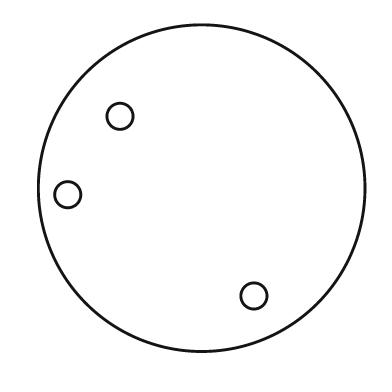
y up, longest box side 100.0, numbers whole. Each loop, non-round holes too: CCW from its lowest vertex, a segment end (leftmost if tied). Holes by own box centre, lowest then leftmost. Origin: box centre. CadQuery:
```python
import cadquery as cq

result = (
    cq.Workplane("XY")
    .moveTo(0.0, 0.0)
    .circle(50.0)
    .moveTo(16.0, -33.0)
    .circle(4.0)
    .moveTo(-41.0, -2.0)
    .circle(4.0)
    .moveTo(-25.0, 22.0)
    .circle(4.0)
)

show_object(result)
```